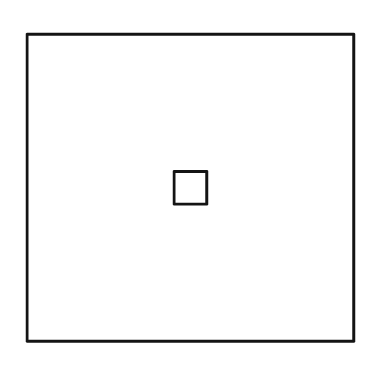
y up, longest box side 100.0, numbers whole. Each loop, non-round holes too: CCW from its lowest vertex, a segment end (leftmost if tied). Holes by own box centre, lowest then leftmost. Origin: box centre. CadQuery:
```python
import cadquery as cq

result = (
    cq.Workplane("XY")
    .moveTo(-50.0, -47.0)
    .lineTo(50.0, -47.0)
    .lineTo(50.0, 47.0)
    .lineTo(-50.0, 47.0)
    .close()
    .moveTo(-5.0, -5.0)
    .lineTo(5.0, -5.0)
    .lineTo(5.0, 5.0)
    .lineTo(-5.0, 5.0)
    .close()
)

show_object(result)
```